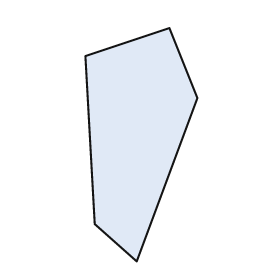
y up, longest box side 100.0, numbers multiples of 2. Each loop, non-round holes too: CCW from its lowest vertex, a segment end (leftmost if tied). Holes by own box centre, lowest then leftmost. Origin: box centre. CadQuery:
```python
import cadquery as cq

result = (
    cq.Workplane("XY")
    .moveTo(-2.0, -50.0)
    .lineTo(24.0, 20.0)
    .lineTo(12.0, 50.0)
    .lineTo(-24.0, 38.0)
    .lineTo(-20.0, -34.0)
    .close()
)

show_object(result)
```